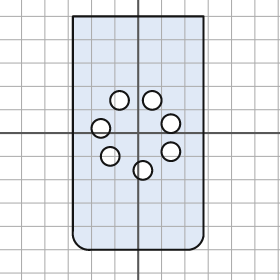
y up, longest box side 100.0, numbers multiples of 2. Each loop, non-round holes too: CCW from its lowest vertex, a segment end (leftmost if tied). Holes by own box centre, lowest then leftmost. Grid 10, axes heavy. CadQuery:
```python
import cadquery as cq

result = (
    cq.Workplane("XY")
    .moveTo(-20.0, -50.0)
    .lineTo(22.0, -50.0)
    .threePointArc((26.0, -48.0), (28.0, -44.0))
    .lineTo(28.0, 50.0)
    .lineTo(-28.0, 50.0)
    .lineTo(-28.0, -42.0)
    .threePointArc((-26.0, -48.0), (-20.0, -50.0))
    .close()
    .moveTo(2.0, -16.0)
    .circle(4.0)
    .moveTo(-12.0, -10.0)
    .circle(4.0)
    .moveTo(14.0, -8.0)
    .circle(4.0)
    .moveTo(-16.0, 2.0)
    .circle(4.0)
    .moveTo(14.0, 4.0)
    .circle(4.0)
    .moveTo(-8.0, 14.0)
    .circle(4.0)
    .moveTo(6.0, 14.0)
    .circle(4.0)
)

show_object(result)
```